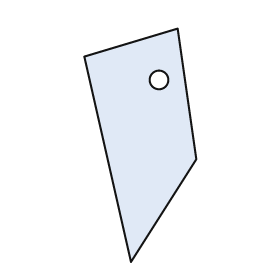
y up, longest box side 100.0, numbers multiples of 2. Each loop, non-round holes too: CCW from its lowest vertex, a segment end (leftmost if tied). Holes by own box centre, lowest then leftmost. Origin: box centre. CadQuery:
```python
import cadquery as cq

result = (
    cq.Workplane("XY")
    .moveTo(-4.0, -50.0)
    .lineTo(24.0, -6.0)
    .lineTo(16.0, 50.0)
    .lineTo(-24.0, 38.0)
    .close()
    .moveTo(8.0, 28.0)
    .circle(4.0)
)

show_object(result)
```